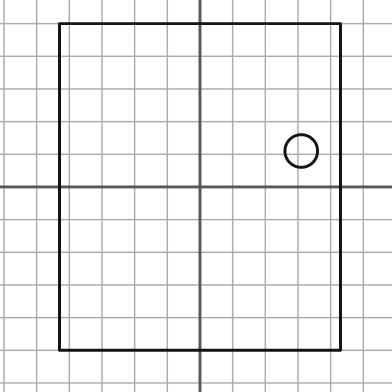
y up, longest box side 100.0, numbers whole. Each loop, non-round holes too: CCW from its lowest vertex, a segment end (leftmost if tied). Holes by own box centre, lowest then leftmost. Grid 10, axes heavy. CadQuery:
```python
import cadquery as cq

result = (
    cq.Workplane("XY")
    .moveTo(-43.0, -50.0)
    .lineTo(43.0, -50.0)
    .lineTo(43.0, 50.0)
    .lineTo(-43.0, 50.0)
    .close()
    .moveTo(31.0, 11.0)
    .circle(5.0)
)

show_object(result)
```